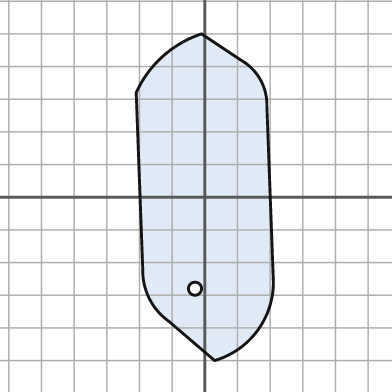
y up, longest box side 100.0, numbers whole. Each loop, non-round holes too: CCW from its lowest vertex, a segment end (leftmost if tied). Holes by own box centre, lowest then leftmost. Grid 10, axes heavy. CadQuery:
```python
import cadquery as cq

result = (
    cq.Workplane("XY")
    .moveTo(3.0, -50.0)
    .threePointArc((16.0, -41.0), (21.0, -26.0))
    .lineTo(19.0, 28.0)
    .threePointArc((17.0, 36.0), (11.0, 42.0))
    .lineTo(-1.0, 50.0)
    .threePointArc((-13.0, 43.0), (-21.0, 32.0))
    .lineTo(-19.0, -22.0)
    .threePointArc((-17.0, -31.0), (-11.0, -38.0))
    .close()
    .moveTo(-3.0, -28.0)
    .circle(2.0)
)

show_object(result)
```